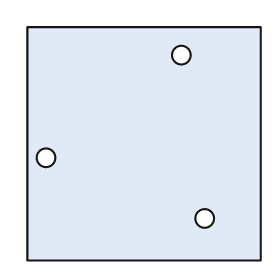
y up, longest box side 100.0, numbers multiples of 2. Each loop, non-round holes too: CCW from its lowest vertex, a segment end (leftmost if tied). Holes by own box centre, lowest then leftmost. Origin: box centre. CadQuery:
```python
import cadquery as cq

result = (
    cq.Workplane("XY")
    .moveTo(-50.0, -50.0)
    .lineTo(50.0, -50.0)
    .lineTo(50.0, 50.0)
    .lineTo(-50.0, 50.0)
    .close()
    .moveTo(26.0, -32.0)
    .circle(4.0)
    .moveTo(-42.0, -6.0)
    .circle(4.0)
    .moveTo(16.0, 38.0)
    .circle(4.0)
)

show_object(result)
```